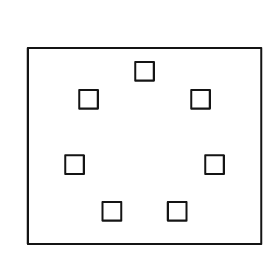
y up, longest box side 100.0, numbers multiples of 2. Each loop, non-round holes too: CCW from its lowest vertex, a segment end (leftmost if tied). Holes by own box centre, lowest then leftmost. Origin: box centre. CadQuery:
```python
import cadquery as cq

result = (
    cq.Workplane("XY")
    .moveTo(-50.0, -42.0)
    .lineTo(50.0, -42.0)
    .lineTo(50.0, 42.0)
    .lineTo(-50.0, 42.0)
    .close()
    .moveTo(-18.0, -32.0)
    .lineTo(-10.0, -32.0)
    .lineTo(-10.0, -24.0)
    .lineTo(-18.0, -24.0)
    .close()
    .moveTo(10.0, -32.0)
    .lineTo(18.0, -32.0)
    .lineTo(18.0, -24.0)
    .lineTo(10.0, -24.0)
    .close()
    .moveTo(-34.0, -12.0)
    .lineTo(-26.0, -12.0)
    .lineTo(-26.0, -4.0)
    .lineTo(-34.0, -4.0)
    .close()
    .moveTo(26.0, -12.0)
    .lineTo(34.0, -12.0)
    .lineTo(34.0, -4.0)
    .lineTo(26.0, -4.0)
    .close()
    .moveTo(-28.0, 16.0)
    .lineTo(-20.0, 16.0)
    .lineTo(-20.0, 24.0)
    .lineTo(-28.0, 24.0)
    .close()
    .moveTo(20.0, 16.0)
    .lineTo(28.0, 16.0)
    .lineTo(28.0, 24.0)
    .lineTo(20.0, 24.0)
    .close()
    .moveTo(-4.0, 28.0)
    .lineTo(4.0, 28.0)
    .lineTo(4.0, 36.0)
    .lineTo(-4.0, 36.0)
    .close()
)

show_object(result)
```